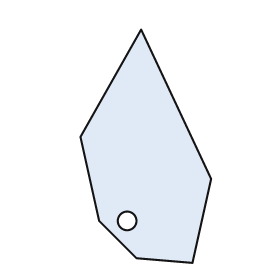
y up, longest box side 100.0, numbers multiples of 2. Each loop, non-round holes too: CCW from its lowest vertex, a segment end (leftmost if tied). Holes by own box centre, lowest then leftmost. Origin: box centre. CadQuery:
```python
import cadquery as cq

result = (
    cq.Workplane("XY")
    .moveTo(20.0, -50.0)
    .lineTo(28.0, -14.0)
    .lineTo(-2.0, 50.0)
    .lineTo(-28.0, 4.0)
    .lineTo(-20.0, -32.0)
    .lineTo(-4.0, -48.0)
    .close()
    .moveTo(-8.0, -32.0)
    .circle(4.0)
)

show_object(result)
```